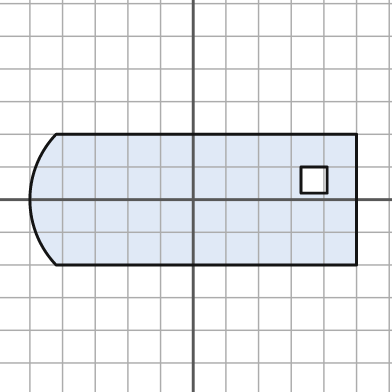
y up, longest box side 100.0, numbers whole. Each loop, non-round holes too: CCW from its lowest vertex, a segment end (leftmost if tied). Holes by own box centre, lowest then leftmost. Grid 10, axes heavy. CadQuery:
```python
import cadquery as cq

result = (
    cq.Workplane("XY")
    .moveTo(-42.0, -20.0)
    .lineTo(50.0, -20.0)
    .lineTo(50.0, 20.0)
    .lineTo(-42.0, 20.0)
    .threePointArc((-50.0, 0.0), (-42.0, -20.0))
    .close()
    .moveTo(33.0, 2.0)
    .lineTo(41.0, 2.0)
    .lineTo(41.0, 10.0)
    .lineTo(33.0, 10.0)
    .close()
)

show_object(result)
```